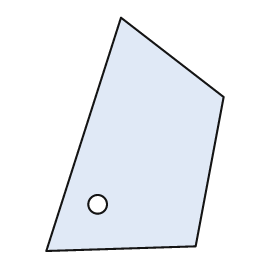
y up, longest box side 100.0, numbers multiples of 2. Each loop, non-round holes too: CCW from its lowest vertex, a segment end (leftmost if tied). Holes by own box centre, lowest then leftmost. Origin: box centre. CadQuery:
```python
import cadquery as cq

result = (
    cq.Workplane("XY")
    .moveTo(-38.0, -50.0)
    .lineTo(26.0, -48.0)
    .lineTo(38.0, 16.0)
    .lineTo(-6.0, 50.0)
    .close()
    .moveTo(-16.0, -30.0)
    .circle(4.0)
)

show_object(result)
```